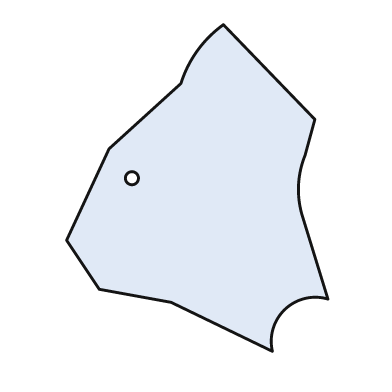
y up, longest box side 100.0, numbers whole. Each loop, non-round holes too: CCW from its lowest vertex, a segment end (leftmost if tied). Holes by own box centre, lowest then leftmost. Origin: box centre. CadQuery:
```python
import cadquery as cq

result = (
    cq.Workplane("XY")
    .moveTo(23.0, -50.0)
    .threePointArc((27.0, -37.0), (40.0, -34.0))
    .lineTo(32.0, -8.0)
    .threePointArc((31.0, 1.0), (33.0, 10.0))
    .lineTo(36.0, 21.0)
    .lineTo(8.0, 50.0)
    .threePointArc((0.0, 42.0), (-5.0, 32.0))
    .lineTo(-27.0, 12.0)
    .lineTo(-40.0, -16.0)
    .lineTo(-30.0, -31.0)
    .lineTo(-8.0, -35.0)
    .close()
    .moveTo(-20.0, 3.0)
    .circle(2.0)
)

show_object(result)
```